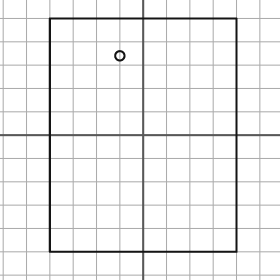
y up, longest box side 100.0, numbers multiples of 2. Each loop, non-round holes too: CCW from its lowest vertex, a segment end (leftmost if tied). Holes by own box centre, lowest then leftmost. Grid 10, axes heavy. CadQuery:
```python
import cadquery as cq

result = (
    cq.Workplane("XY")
    .moveTo(-40.0, -50.0)
    .lineTo(40.0, -50.0)
    .lineTo(40.0, 50.0)
    .lineTo(-40.0, 50.0)
    .close()
    .moveTo(-10.0, 34.0)
    .circle(2.0)
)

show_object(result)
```